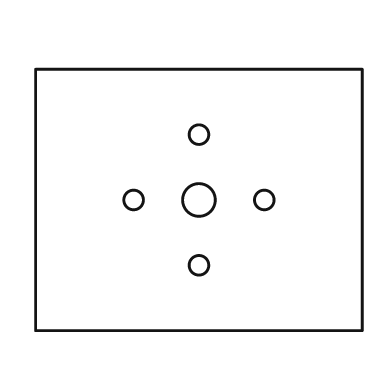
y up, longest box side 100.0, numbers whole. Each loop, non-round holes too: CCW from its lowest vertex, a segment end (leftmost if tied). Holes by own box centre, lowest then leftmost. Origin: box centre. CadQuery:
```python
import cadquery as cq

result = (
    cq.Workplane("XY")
    .moveTo(-50.0, -40.0)
    .lineTo(50.0, -40.0)
    .lineTo(50.0, 40.0)
    .lineTo(-50.0, 40.0)
    .close()
    .moveTo(0.0, -20.0)
    .circle(3.0)
    .moveTo(-20.0, 0.0)
    .circle(3.0)
    .moveTo(0.0, 0.0)
    .circle(5.0)
    .moveTo(20.0, 0.0)
    .circle(3.0)
    .moveTo(0.0, 20.0)
    .circle(3.0)
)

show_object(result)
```